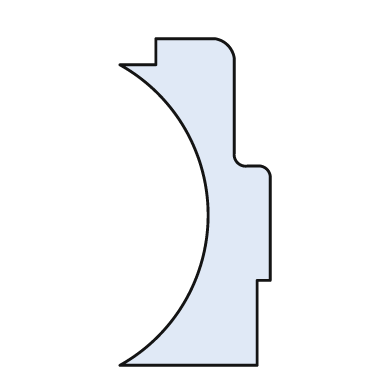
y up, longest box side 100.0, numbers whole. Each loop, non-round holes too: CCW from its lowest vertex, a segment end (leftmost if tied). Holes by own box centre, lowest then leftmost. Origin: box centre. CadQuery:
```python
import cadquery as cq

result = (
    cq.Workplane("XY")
    .moveTo(-23.0, -50.0)
    .lineTo(19.0, -50.0)
    .lineTo(19.0, -24.0)
    .lineTo(23.0, -24.0)
    .lineTo(23.0, 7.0)
    .threePointArc((22.0, 10.0), (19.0, 11.0))
    .lineTo(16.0, 11.0)
    .threePointArc((13.0, 12.0), (12.0, 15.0))
    .lineTo(12.0, 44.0)
    .threePointArc((10.0, 48.0), (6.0, 50.0))
    .lineTo(-12.0, 50.0)
    .lineTo(-12.0, 42.0)
    .lineTo(-23.0, 42.0)
    .threePointArc((4.0, -4.0), (-23.0, -50.0))
    .close()
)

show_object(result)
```